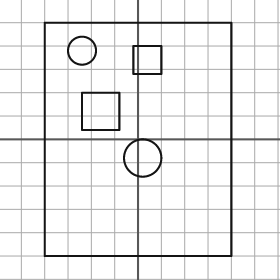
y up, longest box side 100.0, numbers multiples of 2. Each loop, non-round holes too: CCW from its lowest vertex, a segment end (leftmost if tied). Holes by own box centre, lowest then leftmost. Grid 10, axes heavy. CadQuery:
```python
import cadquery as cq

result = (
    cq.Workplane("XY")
    .moveTo(-40.0, -50.0)
    .lineTo(40.0, -50.0)
    .lineTo(40.0, 50.0)
    .lineTo(-40.0, 50.0)
    .close()
    .moveTo(2.0, -8.0)
    .circle(8.0)
    .moveTo(-24.0, 4.0)
    .lineTo(-8.0, 4.0)
    .lineTo(-8.0, 20.0)
    .lineTo(-24.0, 20.0)
    .close()
    .moveTo(-2.0, 28.0)
    .lineTo(10.0, 28.0)
    .lineTo(10.0, 40.0)
    .lineTo(-2.0, 40.0)
    .close()
    .moveTo(-24.0, 38.0)
    .circle(6.0)
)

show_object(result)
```